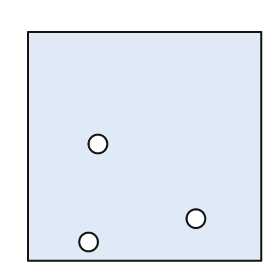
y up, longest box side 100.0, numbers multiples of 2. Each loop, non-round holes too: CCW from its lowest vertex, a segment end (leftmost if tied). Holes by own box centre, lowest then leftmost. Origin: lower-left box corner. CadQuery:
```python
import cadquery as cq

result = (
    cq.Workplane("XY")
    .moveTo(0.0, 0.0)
    .lineTo(100.0, 0.0)
    .lineTo(100.0, 98.0)
    .lineTo(0.0, 98.0)
    .close()
    .moveTo(26.0, 8.0)
    .circle(4.0)
    .moveTo(72.0, 18.0)
    .circle(4.0)
    .moveTo(30.0, 50.0)
    .circle(4.0)
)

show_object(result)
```